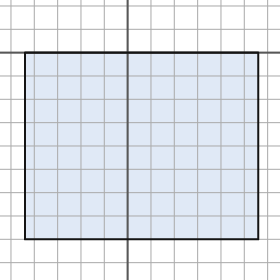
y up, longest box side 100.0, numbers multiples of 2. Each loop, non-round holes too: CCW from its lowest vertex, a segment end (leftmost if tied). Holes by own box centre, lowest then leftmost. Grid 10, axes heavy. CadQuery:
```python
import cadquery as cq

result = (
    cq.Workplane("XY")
    .moveTo(-44.0, -80.0)
    .lineTo(56.0, -80.0)
    .lineTo(56.0, 0.0)
    .lineTo(-44.0, 0.0)
    .close()
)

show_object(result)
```